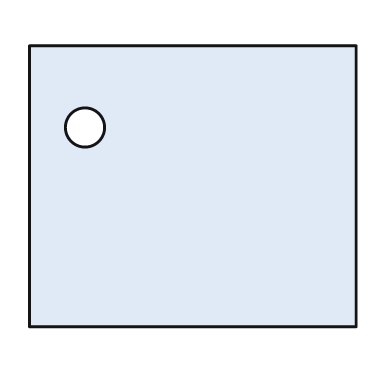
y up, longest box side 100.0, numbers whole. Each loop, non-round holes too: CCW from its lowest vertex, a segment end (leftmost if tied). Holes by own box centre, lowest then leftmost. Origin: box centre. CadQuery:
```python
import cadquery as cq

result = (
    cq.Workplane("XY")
    .moveTo(-50.0, -43.0)
    .lineTo(50.0, -43.0)
    .lineTo(50.0, 43.0)
    .lineTo(-50.0, 43.0)
    .close()
    .moveTo(-33.0, 18.0)
    .circle(6.0)
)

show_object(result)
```